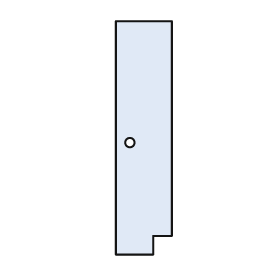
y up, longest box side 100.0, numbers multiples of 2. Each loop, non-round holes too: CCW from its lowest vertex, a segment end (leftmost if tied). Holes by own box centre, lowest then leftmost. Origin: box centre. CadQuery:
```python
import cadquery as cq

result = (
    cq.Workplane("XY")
    .moveTo(-12.0, -50.0)
    .lineTo(4.0, -50.0)
    .lineTo(4.0, -42.0)
    .lineTo(12.0, -42.0)
    .lineTo(12.0, 50.0)
    .lineTo(-12.0, 50.0)
    .close()
    .moveTo(-6.0, -2.0)
    .circle(2.0)
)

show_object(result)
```